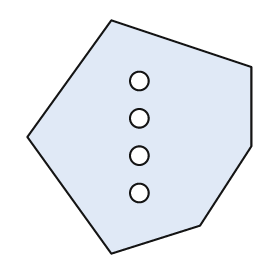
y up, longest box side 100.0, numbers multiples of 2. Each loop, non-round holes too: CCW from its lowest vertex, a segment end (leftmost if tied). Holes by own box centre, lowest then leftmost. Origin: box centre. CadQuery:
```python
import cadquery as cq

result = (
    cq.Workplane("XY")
    .moveTo(-12.0, -50.0)
    .lineTo(26.0, -38.0)
    .lineTo(48.0, -4.0)
    .lineTo(48.0, 30.0)
    .lineTo(-12.0, 50.0)
    .lineTo(-48.0, 0.0)
    .close()
    .moveTo(0.0, -24.0)
    .circle(4.0)
    .moveTo(0.0, -8.0)
    .circle(4.0)
    .moveTo(0.0, 8.0)
    .circle(4.0)
    .moveTo(0.0, 24.0)
    .circle(4.0)
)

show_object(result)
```